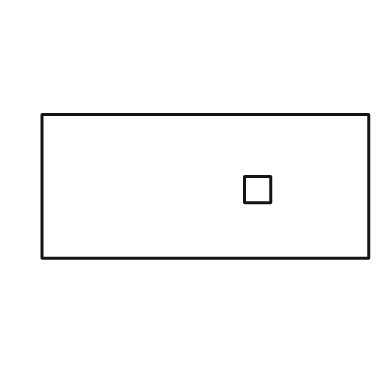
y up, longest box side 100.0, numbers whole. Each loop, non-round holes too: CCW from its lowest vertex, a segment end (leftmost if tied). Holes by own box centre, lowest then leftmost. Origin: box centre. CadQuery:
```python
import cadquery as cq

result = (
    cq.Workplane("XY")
    .moveTo(-50.0, -22.0)
    .lineTo(50.0, -22.0)
    .lineTo(50.0, 22.0)
    .lineTo(-50.0, 22.0)
    .close()
    .moveTo(12.0, -5.0)
    .lineTo(20.0, -5.0)
    .lineTo(20.0, 3.0)
    .lineTo(12.0, 3.0)
    .close()
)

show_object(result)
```